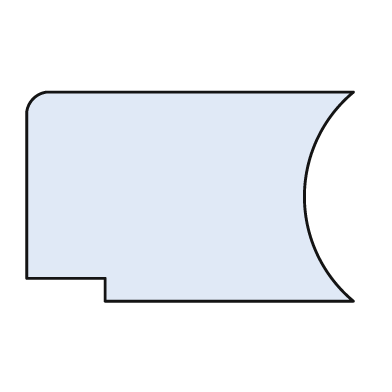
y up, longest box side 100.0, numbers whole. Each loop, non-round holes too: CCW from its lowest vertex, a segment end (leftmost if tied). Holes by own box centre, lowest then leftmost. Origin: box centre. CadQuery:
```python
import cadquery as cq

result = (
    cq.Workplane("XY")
    .moveTo(-26.0, -32.0)
    .lineTo(50.0, -32.0)
    .threePointArc((35.0, 0.0), (50.0, 32.0))
    .lineTo(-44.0, 32.0)
    .threePointArc((-48.0, 30.0), (-50.0, 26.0))
    .lineTo(-50.0, -25.0)
    .lineTo(-26.0, -25.0)
    .close()
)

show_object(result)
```